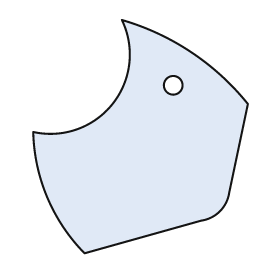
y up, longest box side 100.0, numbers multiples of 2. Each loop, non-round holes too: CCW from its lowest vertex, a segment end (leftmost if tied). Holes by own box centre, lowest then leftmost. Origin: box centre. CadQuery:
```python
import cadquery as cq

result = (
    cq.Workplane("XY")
    .moveTo(-24.0, -50.0)
    .lineTo(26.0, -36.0)
    .threePointArc((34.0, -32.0), (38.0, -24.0))
    .lineTo(46.0, 14.0)
    .threePointArc((22.0, 36.0), (-8.0, 50.0))
    .threePointArc((-12.0, 14.0), (-46.0, 2.0))
    .threePointArc((-40.0, -26.0), (-24.0, -50.0))
    .close()
    .moveTo(14.0, 22.0)
    .circle(4.0)
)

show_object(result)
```